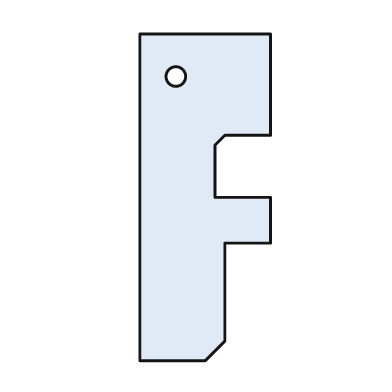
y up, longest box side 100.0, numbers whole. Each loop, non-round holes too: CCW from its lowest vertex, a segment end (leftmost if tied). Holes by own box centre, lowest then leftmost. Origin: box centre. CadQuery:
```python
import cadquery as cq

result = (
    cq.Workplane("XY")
    .moveTo(-20.0, -50.0)
    .lineTo(0.0, -50.0)
    .lineTo(6.0, -44.0)
    .lineTo(6.0, -14.0)
    .lineTo(20.0, -14.0)
    .lineTo(20.0, 0.0)
    .lineTo(3.0, 0.0)
    .lineTo(3.0, 16.0)
    .lineTo(6.0, 19.0)
    .lineTo(20.0, 19.0)
    .lineTo(20.0, 50.0)
    .lineTo(-20.0, 50.0)
    .close()
    .moveTo(-9.0, 37.0)
    .circle(3.0)
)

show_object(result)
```